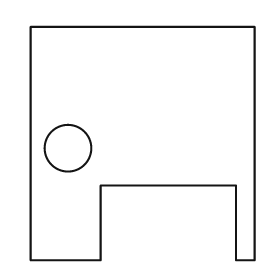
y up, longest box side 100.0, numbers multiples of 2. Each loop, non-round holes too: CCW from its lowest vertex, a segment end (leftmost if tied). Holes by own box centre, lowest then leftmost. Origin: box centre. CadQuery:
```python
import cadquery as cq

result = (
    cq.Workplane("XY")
    .moveTo(-48.0, -50.0)
    .lineTo(-18.0, -50.0)
    .lineTo(-18.0, -18.0)
    .lineTo(40.0, -18.0)
    .lineTo(40.0, -50.0)
    .lineTo(48.0, -50.0)
    .lineTo(48.0, 50.0)
    .lineTo(-48.0, 50.0)
    .close()
    .moveTo(-32.0, -2.0)
    .circle(10.0)
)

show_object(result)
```